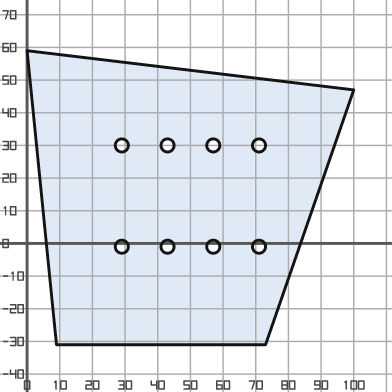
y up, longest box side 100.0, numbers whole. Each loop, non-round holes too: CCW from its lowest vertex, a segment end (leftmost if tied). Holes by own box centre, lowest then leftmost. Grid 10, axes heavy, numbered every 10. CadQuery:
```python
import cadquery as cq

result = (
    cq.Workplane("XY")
    .moveTo(9.0, -31.0)
    .lineTo(73.0, -31.0)
    .lineTo(100.0, 47.0)
    .lineTo(0.0, 59.0)
    .close()
    .moveTo(29.0, -1.0)
    .circle(2.0)
    .moveTo(43.0, -1.0)
    .circle(2.0)
    .moveTo(57.0, -1.0)
    .circle(2.0)
    .moveTo(71.0, -1.0)
    .circle(2.0)
    .moveTo(29.0, 30.0)
    .circle(2.0)
    .moveTo(43.0, 30.0)
    .circle(2.0)
    .moveTo(57.0, 30.0)
    .circle(2.0)
    .moveTo(71.0, 30.0)
    .circle(2.0)
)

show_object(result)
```